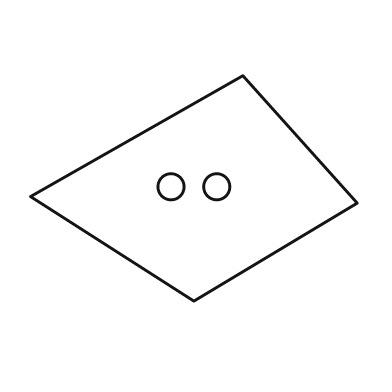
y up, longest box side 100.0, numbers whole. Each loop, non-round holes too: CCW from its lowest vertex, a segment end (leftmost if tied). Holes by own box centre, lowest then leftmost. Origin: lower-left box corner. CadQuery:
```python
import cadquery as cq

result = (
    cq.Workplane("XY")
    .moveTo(50.0, 0.0)
    .lineTo(100.0, 30.0)
    .lineTo(65.0, 69.0)
    .lineTo(0.0, 32.0)
    .close()
    .moveTo(43.0, 35.0)
    .circle(4.0)
    .moveTo(57.0, 35.0)
    .circle(4.0)
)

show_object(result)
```